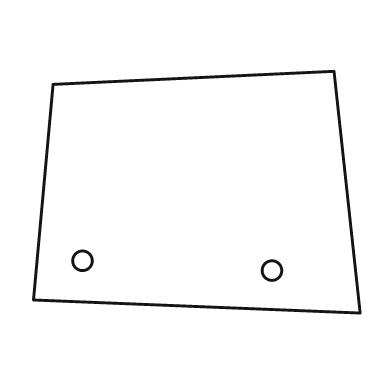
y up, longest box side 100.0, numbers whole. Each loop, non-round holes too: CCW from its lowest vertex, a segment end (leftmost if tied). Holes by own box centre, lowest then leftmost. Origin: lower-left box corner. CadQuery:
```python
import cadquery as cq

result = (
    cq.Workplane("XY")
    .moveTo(100.0, 0.0)
    .lineTo(92.0, 74.0)
    .lineTo(6.0, 70.0)
    .lineTo(0.0, 4.0)
    .close()
    .moveTo(73.0, 13.0)
    .circle(3.0)
    .moveTo(15.0, 16.0)
    .circle(3.0)
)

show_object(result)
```